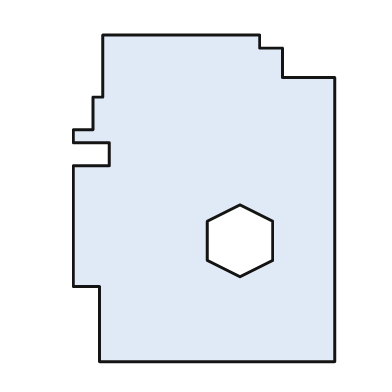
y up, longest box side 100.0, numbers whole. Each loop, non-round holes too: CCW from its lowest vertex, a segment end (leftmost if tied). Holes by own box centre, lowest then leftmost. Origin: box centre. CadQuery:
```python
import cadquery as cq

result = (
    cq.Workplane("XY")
    .moveTo(-32.0, -50.0)
    .lineTo(40.0, -50.0)
    .lineTo(40.0, 37.0)
    .lineTo(24.0, 37.0)
    .lineTo(24.0, 46.0)
    .lineTo(17.0, 46.0)
    .lineTo(17.0, 50.0)
    .lineTo(-31.0, 50.0)
    .lineTo(-31.0, 31.0)
    .lineTo(-34.0, 31.0)
    .lineTo(-34.0, 21.0)
    .lineTo(-40.0, 21.0)
    .lineTo(-40.0, 17.0)
    .lineTo(-29.0, 17.0)
    .lineTo(-29.0, 10.0)
    .lineTo(-40.0, 10.0)
    .lineTo(-40.0, -27.0)
    .lineTo(-32.0, -27.0)
    .close()
    .moveTo(11.0, -24.0)
    .lineTo(21.0, -19.0)
    .lineTo(21.0, -7.0)
    .lineTo(11.0, -2.0)
    .lineTo(1.0, -7.0)
    .lineTo(1.0, -19.0)
    .close()
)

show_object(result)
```